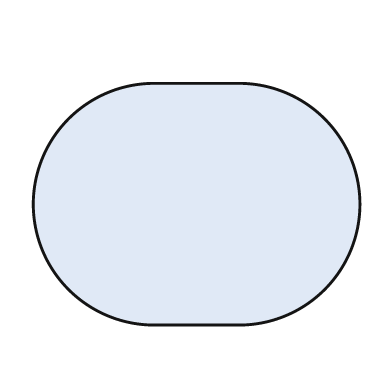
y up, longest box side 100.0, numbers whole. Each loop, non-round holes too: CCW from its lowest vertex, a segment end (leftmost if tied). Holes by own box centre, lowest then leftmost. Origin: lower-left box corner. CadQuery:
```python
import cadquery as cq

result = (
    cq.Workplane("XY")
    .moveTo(37.0, 0.0)
    .lineTo(63.0, 0.0)
    .threePointArc((100.0, 37.0), (63.0, 74.0))
    .lineTo(37.0, 74.0)
    .threePointArc((0.0, 37.0), (37.0, 0.0))
    .close()
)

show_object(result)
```